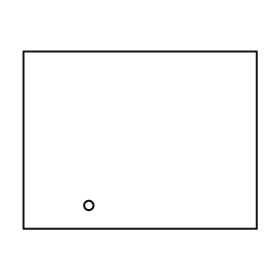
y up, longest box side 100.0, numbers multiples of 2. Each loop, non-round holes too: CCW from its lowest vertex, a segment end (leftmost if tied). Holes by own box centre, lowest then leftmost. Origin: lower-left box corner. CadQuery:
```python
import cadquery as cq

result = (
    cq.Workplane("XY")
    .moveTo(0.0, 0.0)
    .lineTo(100.0, 0.0)
    .lineTo(100.0, 76.0)
    .lineTo(0.0, 76.0)
    .close()
    .moveTo(28.0, 10.0)
    .circle(2.0)
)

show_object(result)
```